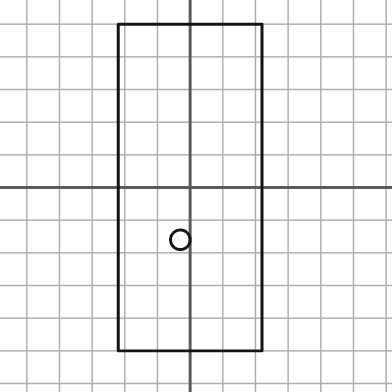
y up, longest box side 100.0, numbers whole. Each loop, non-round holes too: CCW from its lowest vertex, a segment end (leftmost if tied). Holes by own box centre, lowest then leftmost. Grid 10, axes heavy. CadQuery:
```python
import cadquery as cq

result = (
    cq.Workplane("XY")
    .moveTo(-22.0, -50.0)
    .lineTo(22.0, -50.0)
    .lineTo(22.0, 50.0)
    .lineTo(-22.0, 50.0)
    .close()
    .moveTo(-3.0, -16.0)
    .circle(3.0)
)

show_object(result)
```